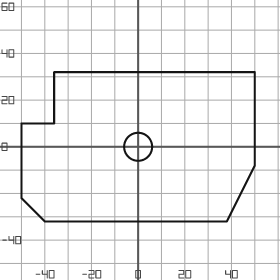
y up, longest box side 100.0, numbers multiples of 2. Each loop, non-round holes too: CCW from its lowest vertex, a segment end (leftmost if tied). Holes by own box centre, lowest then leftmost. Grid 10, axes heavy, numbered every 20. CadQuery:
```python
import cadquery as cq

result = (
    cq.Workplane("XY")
    .moveTo(-40.0, -32.0)
    .lineTo(38.0, -32.0)
    .lineTo(50.0, -8.0)
    .lineTo(50.0, 32.0)
    .lineTo(-36.0, 32.0)
    .lineTo(-36.0, 10.0)
    .lineTo(-50.0, 10.0)
    .lineTo(-50.0, -22.0)
    .close()
    .moveTo(0.0, 0.0)
    .circle(6.0)
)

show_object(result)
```